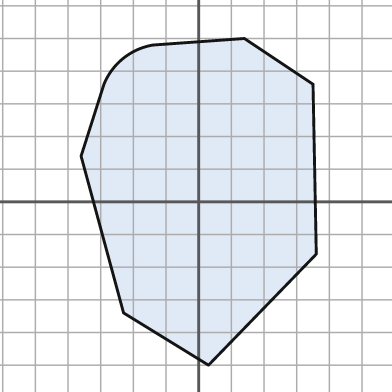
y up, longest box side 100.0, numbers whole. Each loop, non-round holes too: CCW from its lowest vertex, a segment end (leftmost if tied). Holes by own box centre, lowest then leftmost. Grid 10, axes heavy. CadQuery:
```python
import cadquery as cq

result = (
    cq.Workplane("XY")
    .moveTo(3.0, -50.0)
    .lineTo(36.0, -16.0)
    .lineTo(35.0, 36.0)
    .lineTo(14.0, 50.0)
    .lineTo(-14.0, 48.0)
    .threePointArc((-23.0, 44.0), (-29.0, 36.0))
    .lineTo(-36.0, 14.0)
    .lineTo(-23.0, -34.0)
    .close()
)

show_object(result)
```